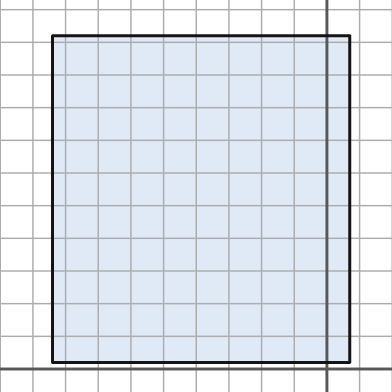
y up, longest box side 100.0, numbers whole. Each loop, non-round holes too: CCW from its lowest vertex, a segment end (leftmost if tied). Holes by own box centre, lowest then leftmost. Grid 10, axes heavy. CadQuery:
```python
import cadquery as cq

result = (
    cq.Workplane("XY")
    .moveTo(-84.0, 2.0)
    .lineTo(7.0, 2.0)
    .lineTo(7.0, 102.0)
    .lineTo(-84.0, 102.0)
    .close()
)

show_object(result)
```